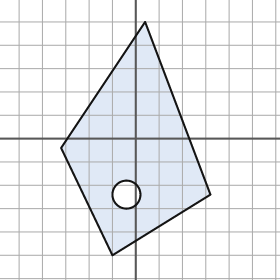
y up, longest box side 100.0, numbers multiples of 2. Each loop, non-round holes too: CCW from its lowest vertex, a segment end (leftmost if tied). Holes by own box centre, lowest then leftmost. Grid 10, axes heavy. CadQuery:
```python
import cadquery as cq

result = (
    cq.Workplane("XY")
    .moveTo(-10.0, -50.0)
    .lineTo(32.0, -24.0)
    .lineTo(4.0, 50.0)
    .lineTo(-32.0, -4.0)
    .close()
    .moveTo(-4.0, -24.0)
    .circle(6.0)
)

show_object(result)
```